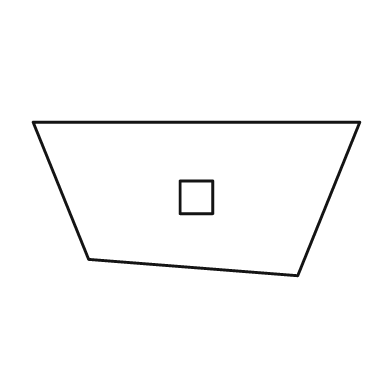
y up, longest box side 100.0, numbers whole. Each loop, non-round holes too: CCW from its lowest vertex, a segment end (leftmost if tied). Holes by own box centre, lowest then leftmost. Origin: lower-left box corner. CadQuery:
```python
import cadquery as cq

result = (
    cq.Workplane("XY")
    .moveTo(81.0, 0.0)
    .lineTo(100.0, 47.0)
    .lineTo(0.0, 47.0)
    .lineTo(17.0, 5.0)
    .close()
    .moveTo(45.0, 19.0)
    .lineTo(55.0, 19.0)
    .lineTo(55.0, 29.0)
    .lineTo(45.0, 29.0)
    .close()
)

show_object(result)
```